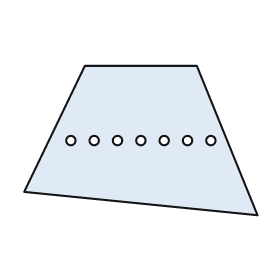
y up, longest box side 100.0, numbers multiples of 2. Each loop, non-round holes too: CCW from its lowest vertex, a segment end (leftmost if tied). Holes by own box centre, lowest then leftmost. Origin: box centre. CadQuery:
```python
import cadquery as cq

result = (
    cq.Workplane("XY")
    .moveTo(50.0, -32.0)
    .lineTo(24.0, 32.0)
    .lineTo(-24.0, 32.0)
    .lineTo(-50.0, -22.0)
    .close()
    .moveTo(-30.0, 0.0)
    .circle(2.0)
    .moveTo(-20.0, 0.0)
    .circle(2.0)
    .moveTo(-10.0, 0.0)
    .circle(2.0)
    .moveTo(0.0, 0.0)
    .circle(2.0)
    .moveTo(10.0, 0.0)
    .circle(2.0)
    .moveTo(20.0, 0.0)
    .circle(2.0)
    .moveTo(30.0, 0.0)
    .circle(2.0)
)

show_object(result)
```